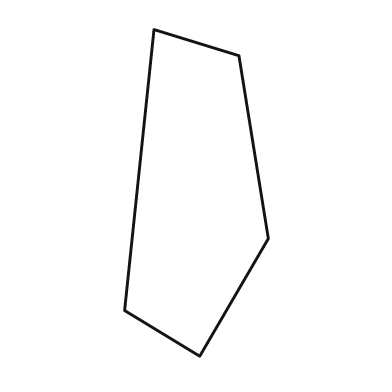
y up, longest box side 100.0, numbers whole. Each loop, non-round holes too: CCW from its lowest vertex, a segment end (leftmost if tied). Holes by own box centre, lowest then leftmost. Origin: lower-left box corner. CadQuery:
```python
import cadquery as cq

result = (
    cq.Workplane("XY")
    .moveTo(23.0, 0.0)
    .lineTo(44.0, 36.0)
    .lineTo(35.0, 92.0)
    .lineTo(9.0, 100.0)
    .lineTo(0.0, 14.0)
    .close()
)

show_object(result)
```